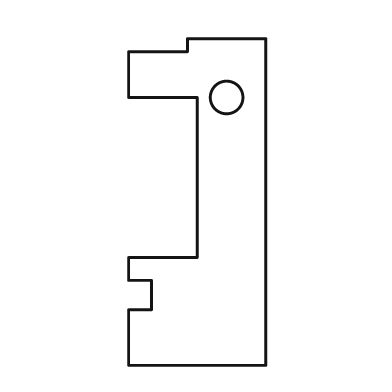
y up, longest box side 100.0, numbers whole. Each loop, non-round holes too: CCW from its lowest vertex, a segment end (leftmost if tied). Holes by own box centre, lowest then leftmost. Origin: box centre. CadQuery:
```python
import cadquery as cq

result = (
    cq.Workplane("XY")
    .moveTo(-21.0, -50.0)
    .lineTo(21.0, -50.0)
    .lineTo(21.0, 50.0)
    .lineTo(-3.0, 50.0)
    .lineTo(-3.0, 46.0)
    .lineTo(-21.0, 46.0)
    .lineTo(-21.0, 32.0)
    .lineTo(0.0, 32.0)
    .lineTo(0.0, -17.0)
    .lineTo(-21.0, -17.0)
    .lineTo(-21.0, -24.0)
    .lineTo(-14.0, -24.0)
    .lineTo(-14.0, -33.0)
    .lineTo(-21.0, -33.0)
    .close()
    .moveTo(9.0, 32.0)
    .circle(5.0)
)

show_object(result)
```